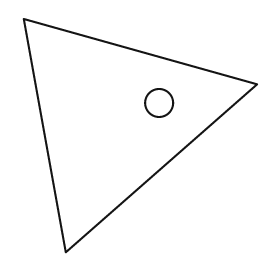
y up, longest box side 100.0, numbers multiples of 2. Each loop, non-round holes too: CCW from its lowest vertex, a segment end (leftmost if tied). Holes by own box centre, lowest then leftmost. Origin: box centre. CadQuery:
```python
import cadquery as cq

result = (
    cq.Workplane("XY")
    .moveTo(-32.0, -50.0)
    .lineTo(50.0, 22.0)
    .lineTo(-50.0, 50.0)
    .close()
    .moveTo(8.0, 14.0)
    .circle(6.0)
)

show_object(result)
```